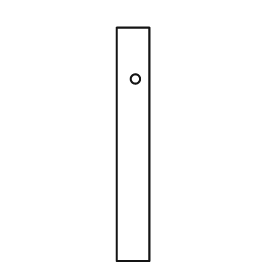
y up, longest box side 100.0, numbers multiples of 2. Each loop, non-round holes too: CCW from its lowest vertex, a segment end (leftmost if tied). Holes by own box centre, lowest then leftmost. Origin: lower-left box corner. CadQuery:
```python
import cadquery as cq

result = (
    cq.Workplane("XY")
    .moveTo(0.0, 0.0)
    .lineTo(14.0, 0.0)
    .lineTo(14.0, 100.0)
    .lineTo(0.0, 100.0)
    .close()
    .moveTo(8.0, 78.0)
    .circle(2.0)
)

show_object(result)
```